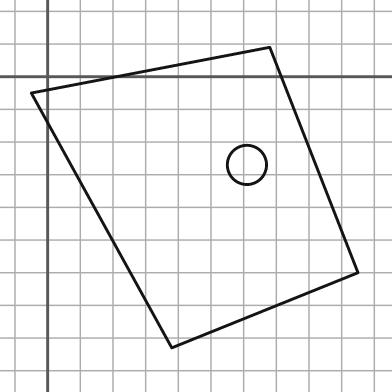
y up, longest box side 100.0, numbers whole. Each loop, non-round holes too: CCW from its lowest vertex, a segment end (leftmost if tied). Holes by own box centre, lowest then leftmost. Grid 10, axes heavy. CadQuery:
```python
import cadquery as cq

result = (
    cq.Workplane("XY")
    .moveTo(38.0, -83.0)
    .lineTo(95.0, -60.0)
    .lineTo(68.0, 9.0)
    .lineTo(-5.0, -5.0)
    .close()
    .moveTo(61.0, -27.0)
    .circle(6.0)
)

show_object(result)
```